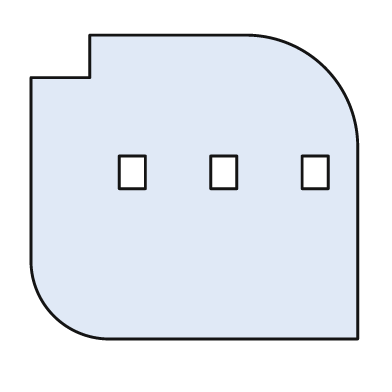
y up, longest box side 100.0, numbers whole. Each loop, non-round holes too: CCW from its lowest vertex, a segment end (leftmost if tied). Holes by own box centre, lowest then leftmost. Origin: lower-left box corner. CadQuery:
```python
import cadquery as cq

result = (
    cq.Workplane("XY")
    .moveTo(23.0, 0.0)
    .lineTo(100.0, 0.0)
    .lineTo(100.0, 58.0)
    .threePointArc((90.0, 83.0), (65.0, 93.0))
    .lineTo(18.0, 93.0)
    .lineTo(18.0, 80.0)
    .lineTo(0.0, 80.0)
    .lineTo(0.0, 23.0)
    .threePointArc((7.0, 7.0), (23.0, 0.0))
    .close()
    .moveTo(27.0, 46.0)
    .lineTo(35.0, 46.0)
    .lineTo(35.0, 56.0)
    .lineTo(27.0, 56.0)
    .close()
    .moveTo(55.0, 46.0)
    .lineTo(63.0, 46.0)
    .lineTo(63.0, 56.0)
    .lineTo(55.0, 56.0)
    .close()
    .moveTo(83.0, 46.0)
    .lineTo(91.0, 46.0)
    .lineTo(91.0, 56.0)
    .lineTo(83.0, 56.0)
    .close()
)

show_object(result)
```